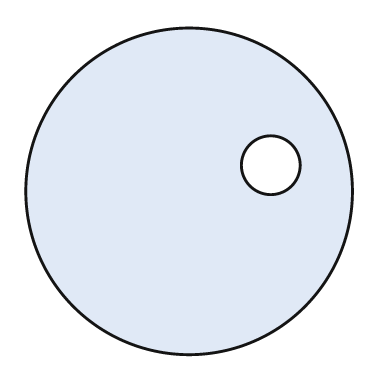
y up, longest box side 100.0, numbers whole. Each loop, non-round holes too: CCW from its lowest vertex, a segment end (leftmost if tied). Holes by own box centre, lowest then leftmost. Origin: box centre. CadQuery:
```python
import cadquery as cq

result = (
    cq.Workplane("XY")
    .moveTo(0.0, 0.0)
    .circle(50.0)
    .moveTo(25.0, 8.0)
    .circle(9.0)
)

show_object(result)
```